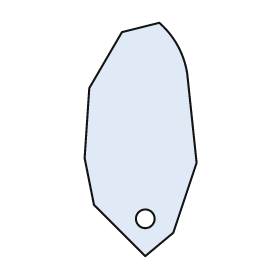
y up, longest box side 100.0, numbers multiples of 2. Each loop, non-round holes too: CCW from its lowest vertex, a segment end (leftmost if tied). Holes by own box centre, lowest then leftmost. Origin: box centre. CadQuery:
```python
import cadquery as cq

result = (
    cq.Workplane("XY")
    .moveTo(2.0, -50.0)
    .lineTo(14.0, -40.0)
    .lineTo(24.0, -10.0)
    .lineTo(20.0, 28.0)
    .threePointArc((16.0, 40.0), (8.0, 50.0))
    .lineTo(-8.0, 46.0)
    .lineTo(-22.0, 22.0)
    .lineTo(-24.0, -8.0)
    .lineTo(-20.0, -28.0)
    .close()
    .moveTo(2.0, -34.0)
    .circle(4.0)
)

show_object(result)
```